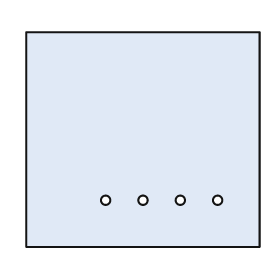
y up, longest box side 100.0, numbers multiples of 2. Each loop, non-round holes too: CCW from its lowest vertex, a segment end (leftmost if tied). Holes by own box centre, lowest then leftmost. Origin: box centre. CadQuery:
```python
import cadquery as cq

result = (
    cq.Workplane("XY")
    .moveTo(-50.0, -46.0)
    .lineTo(50.0, -46.0)
    .lineTo(50.0, 46.0)
    .lineTo(-50.0, 46.0)
    .close()
    .moveTo(-16.0, -26.0)
    .circle(2.0)
    .moveTo(0.0, -26.0)
    .circle(2.0)
    .moveTo(16.0, -26.0)
    .circle(2.0)
    .moveTo(32.0, -26.0)
    .circle(2.0)
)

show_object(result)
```